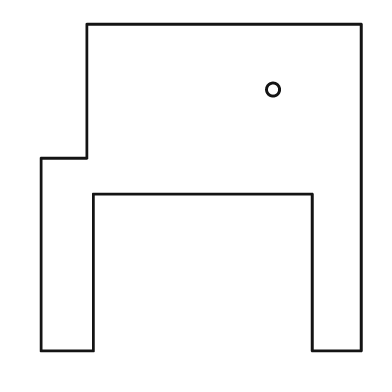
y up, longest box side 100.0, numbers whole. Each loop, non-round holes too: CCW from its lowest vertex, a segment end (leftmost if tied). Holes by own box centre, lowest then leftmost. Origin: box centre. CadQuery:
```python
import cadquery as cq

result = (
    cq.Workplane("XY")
    .moveTo(-49.0, -50.0)
    .lineTo(-33.0, -50.0)
    .lineTo(-33.0, -2.0)
    .lineTo(34.0, -2.0)
    .lineTo(34.0, -50.0)
    .lineTo(49.0, -50.0)
    .lineTo(49.0, 50.0)
    .lineTo(-35.0, 50.0)
    .lineTo(-35.0, 9.0)
    .lineTo(-49.0, 9.0)
    .close()
    .moveTo(22.0, 30.0)
    .circle(2.0)
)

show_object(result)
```